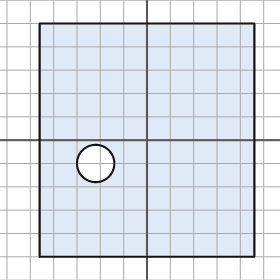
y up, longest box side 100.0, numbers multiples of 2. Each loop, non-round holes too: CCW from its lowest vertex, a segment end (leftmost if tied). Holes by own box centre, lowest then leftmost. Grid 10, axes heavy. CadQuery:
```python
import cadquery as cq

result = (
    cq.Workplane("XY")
    .moveTo(-46.0, -50.0)
    .lineTo(46.0, -50.0)
    .lineTo(46.0, 50.0)
    .lineTo(-46.0, 50.0)
    .close()
    .moveTo(-22.0, -10.0)
    .circle(8.0)
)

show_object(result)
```